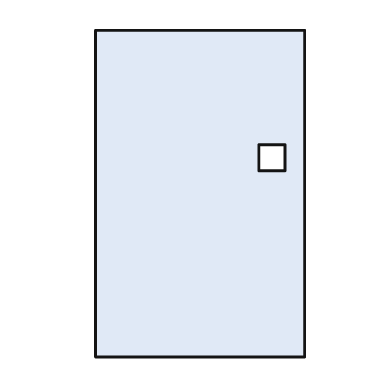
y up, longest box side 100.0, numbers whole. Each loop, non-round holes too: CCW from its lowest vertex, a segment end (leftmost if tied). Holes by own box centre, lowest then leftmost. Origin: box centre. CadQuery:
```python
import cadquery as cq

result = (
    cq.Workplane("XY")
    .moveTo(-32.0, -50.0)
    .lineTo(32.0, -50.0)
    .lineTo(32.0, 50.0)
    .lineTo(-32.0, 50.0)
    .close()
    .moveTo(18.0, 7.0)
    .lineTo(26.0, 7.0)
    .lineTo(26.0, 15.0)
    .lineTo(18.0, 15.0)
    .close()
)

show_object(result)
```